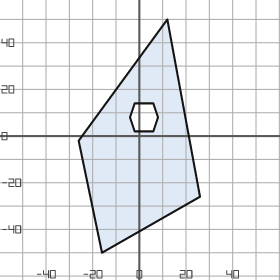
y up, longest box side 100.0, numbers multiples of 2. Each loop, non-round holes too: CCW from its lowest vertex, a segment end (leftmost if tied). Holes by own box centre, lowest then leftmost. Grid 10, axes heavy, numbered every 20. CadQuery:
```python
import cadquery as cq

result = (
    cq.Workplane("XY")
    .moveTo(-16.0, -50.0)
    .lineTo(26.0, -26.0)
    .lineTo(12.0, 50.0)
    .lineTo(-26.0, -2.0)
    .close()
    .moveTo(-2.0, 2.0)
    .lineTo(6.0, 2.0)
    .lineTo(8.0, 8.0)
    .lineTo(6.0, 14.0)
    .lineTo(-2.0, 14.0)
    .lineTo(-4.0, 8.0)
    .close()
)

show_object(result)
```